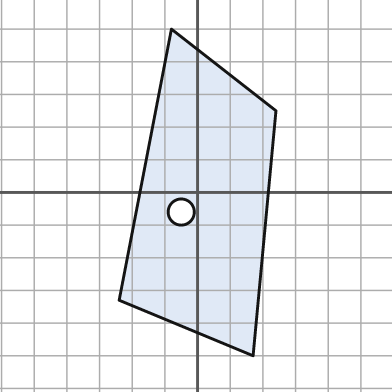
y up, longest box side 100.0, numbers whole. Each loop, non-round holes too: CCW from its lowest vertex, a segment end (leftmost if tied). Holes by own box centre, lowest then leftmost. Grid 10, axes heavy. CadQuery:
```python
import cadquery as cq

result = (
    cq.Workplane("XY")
    .moveTo(17.0, -50.0)
    .lineTo(24.0, 25.0)
    .lineTo(-8.0, 50.0)
    .lineTo(-24.0, -33.0)
    .close()
    .moveTo(-5.0, -6.0)
    .circle(4.0)
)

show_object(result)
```